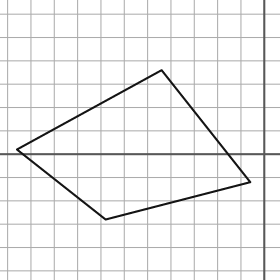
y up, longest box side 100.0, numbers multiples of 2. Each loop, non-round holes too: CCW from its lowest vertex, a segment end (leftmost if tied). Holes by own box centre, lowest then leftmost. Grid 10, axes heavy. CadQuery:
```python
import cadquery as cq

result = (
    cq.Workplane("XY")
    .moveTo(-68.0, -28.0)
    .lineTo(-6.0, -12.0)
    .lineTo(-44.0, 36.0)
    .lineTo(-106.0, 2.0)
    .close()
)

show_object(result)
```